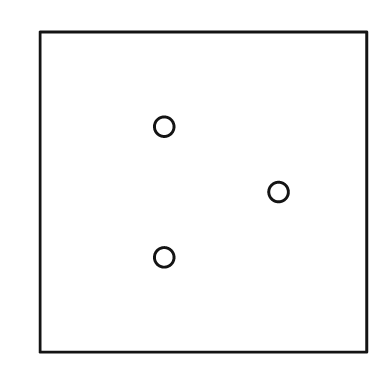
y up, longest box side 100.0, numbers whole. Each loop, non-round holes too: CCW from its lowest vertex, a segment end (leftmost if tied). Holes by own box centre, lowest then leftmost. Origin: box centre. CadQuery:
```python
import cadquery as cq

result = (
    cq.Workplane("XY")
    .moveTo(-50.0, -49.0)
    .lineTo(50.0, -49.0)
    .lineTo(50.0, 49.0)
    .lineTo(-50.0, 49.0)
    .close()
    .moveTo(-12.0, -20.0)
    .circle(3.0)
    .moveTo(23.0, 0.0)
    .circle(3.0)
    .moveTo(-12.0, 20.0)
    .circle(3.0)
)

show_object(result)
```